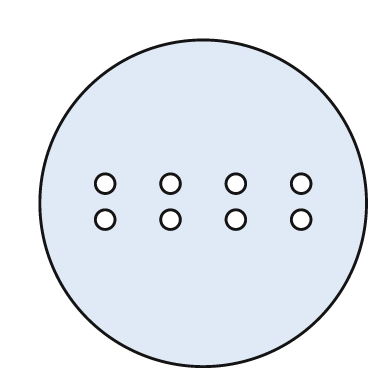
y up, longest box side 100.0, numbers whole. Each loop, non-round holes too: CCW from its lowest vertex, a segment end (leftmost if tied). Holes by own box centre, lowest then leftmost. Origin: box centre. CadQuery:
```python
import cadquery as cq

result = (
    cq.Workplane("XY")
    .moveTo(0.0, 0.0)
    .circle(50.0)
    .moveTo(-30.0, -5.0)
    .circle(3.0)
    .moveTo(-10.0, -5.0)
    .circle(3.0)
    .moveTo(10.0, -5.0)
    .circle(3.0)
    .moveTo(30.0, -5.0)
    .circle(3.0)
    .moveTo(-30.0, 6.0)
    .circle(3.0)
    .moveTo(-10.0, 6.0)
    .circle(3.0)
    .moveTo(10.0, 6.0)
    .circle(3.0)
    .moveTo(30.0, 6.0)
    .circle(3.0)
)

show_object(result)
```